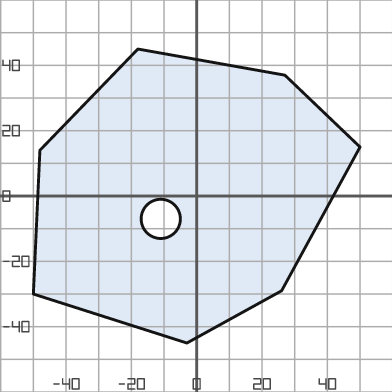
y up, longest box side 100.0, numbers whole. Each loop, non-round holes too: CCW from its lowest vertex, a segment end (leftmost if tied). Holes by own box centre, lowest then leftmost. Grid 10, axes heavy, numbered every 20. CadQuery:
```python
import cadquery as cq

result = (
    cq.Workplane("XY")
    .moveTo(-3.0, -45.0)
    .lineTo(26.0, -29.0)
    .lineTo(50.0, 15.0)
    .lineTo(27.0, 37.0)
    .lineTo(-18.0, 45.0)
    .lineTo(-48.0, 14.0)
    .lineTo(-50.0, -30.0)
    .close()
    .moveTo(-11.0, -7.0)
    .circle(6.0)
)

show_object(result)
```